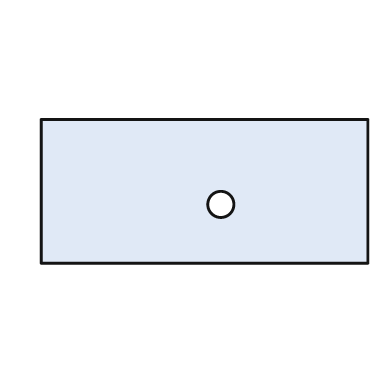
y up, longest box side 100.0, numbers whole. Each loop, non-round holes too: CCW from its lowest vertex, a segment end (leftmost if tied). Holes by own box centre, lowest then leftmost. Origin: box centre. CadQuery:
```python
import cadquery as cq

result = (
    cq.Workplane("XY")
    .moveTo(-50.0, -22.0)
    .lineTo(50.0, -22.0)
    .lineTo(50.0, 22.0)
    .lineTo(-50.0, 22.0)
    .close()
    .moveTo(5.0, -4.0)
    .circle(4.0)
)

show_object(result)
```